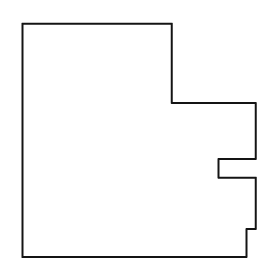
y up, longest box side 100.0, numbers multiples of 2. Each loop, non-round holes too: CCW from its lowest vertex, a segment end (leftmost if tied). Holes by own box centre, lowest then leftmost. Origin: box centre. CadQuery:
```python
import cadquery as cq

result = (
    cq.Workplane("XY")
    .moveTo(-50.0, -50.0)
    .lineTo(46.0, -50.0)
    .lineTo(46.0, -38.0)
    .lineTo(50.0, -38.0)
    .lineTo(50.0, -16.0)
    .lineTo(34.0, -16.0)
    .lineTo(34.0, -8.0)
    .lineTo(50.0, -8.0)
    .lineTo(50.0, 16.0)
    .lineTo(14.0, 16.0)
    .lineTo(14.0, 50.0)
    .lineTo(-50.0, 50.0)
    .close()
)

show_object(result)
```